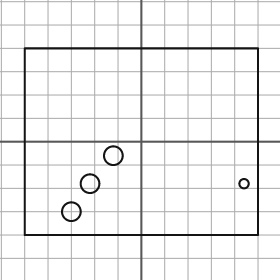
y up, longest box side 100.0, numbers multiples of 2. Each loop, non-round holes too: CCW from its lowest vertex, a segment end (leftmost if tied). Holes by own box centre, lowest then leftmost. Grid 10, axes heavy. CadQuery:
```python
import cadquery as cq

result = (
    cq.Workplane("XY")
    .moveTo(-50.0, -40.0)
    .lineTo(50.0, -40.0)
    .lineTo(50.0, 40.0)
    .lineTo(-50.0, 40.0)
    .close()
    .moveTo(-30.0, -30.0)
    .circle(4.0)
    .moveTo(-22.0, -18.0)
    .circle(4.0)
    .moveTo(44.0, -18.0)
    .circle(2.0)
    .moveTo(-12.0, -6.0)
    .circle(4.0)
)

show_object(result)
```